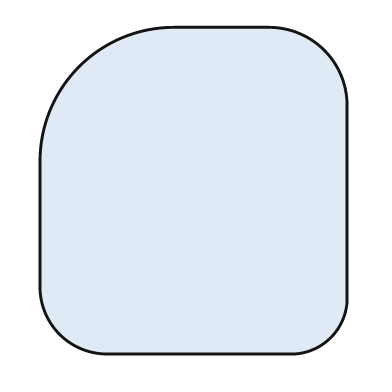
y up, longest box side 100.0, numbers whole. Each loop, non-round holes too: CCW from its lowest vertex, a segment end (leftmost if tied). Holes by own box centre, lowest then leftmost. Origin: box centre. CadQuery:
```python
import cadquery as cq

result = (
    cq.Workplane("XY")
    .moveTo(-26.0, -50.0)
    .lineTo(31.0, -50.0)
    .threePointArc((42.0, -45.0), (47.0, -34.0))
    .lineTo(47.0, 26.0)
    .threePointArc((40.0, 43.0), (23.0, 50.0))
    .lineTo(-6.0, 50.0)
    .threePointArc((-35.0, 38.0), (-47.0, 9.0))
    .lineTo(-47.0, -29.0)
    .threePointArc((-41.0, -44.0), (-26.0, -50.0))
    .close()
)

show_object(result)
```